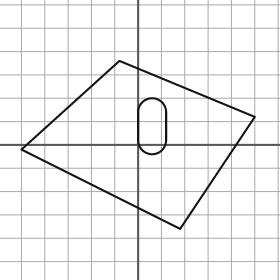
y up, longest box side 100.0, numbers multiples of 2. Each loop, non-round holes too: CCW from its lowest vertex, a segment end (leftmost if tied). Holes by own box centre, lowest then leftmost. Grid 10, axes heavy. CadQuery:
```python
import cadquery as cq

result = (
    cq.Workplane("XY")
    .moveTo(18.0, -36.0)
    .lineTo(50.0, 12.0)
    .lineTo(-8.0, 36.0)
    .lineTo(-50.0, -2.0)
    .close()
    .moveTo(0.0, 2.0)
    .threePointArc((6.0, -4.0), (12.0, 2.0))
    .lineTo(12.0, 14.0)
    .threePointArc((6.0, 20.0), (0.0, 14.0))
    .close()
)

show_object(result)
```